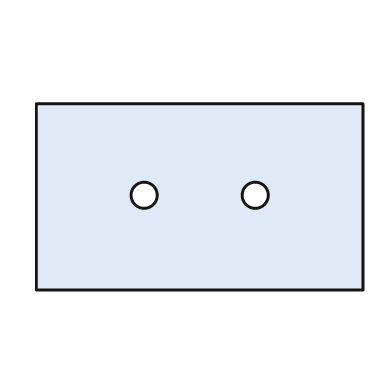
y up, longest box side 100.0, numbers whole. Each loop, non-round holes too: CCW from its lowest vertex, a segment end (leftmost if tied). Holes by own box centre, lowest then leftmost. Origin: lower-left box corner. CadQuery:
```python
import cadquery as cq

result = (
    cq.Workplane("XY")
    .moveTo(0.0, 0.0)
    .lineTo(100.0, 0.0)
    .lineTo(100.0, 57.0)
    .lineTo(0.0, 57.0)
    .close()
    .moveTo(33.0, 29.0)
    .circle(4.0)
    .moveTo(67.0, 29.0)
    .circle(4.0)
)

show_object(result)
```